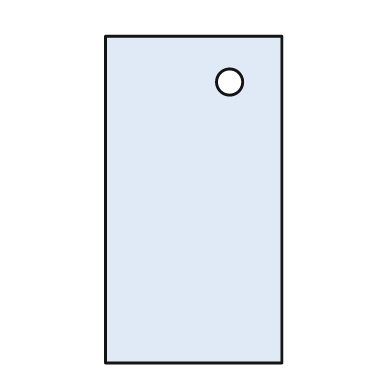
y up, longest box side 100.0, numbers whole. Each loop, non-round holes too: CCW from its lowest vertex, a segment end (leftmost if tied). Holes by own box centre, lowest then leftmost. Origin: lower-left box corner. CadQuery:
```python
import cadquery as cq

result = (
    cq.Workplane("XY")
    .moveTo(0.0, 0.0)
    .lineTo(54.0, 0.0)
    .lineTo(54.0, 100.0)
    .lineTo(0.0, 100.0)
    .close()
    .moveTo(38.0, 86.0)
    .circle(4.0)
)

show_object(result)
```